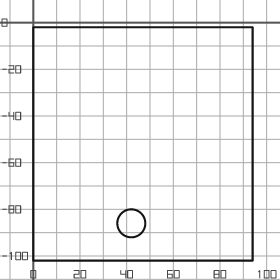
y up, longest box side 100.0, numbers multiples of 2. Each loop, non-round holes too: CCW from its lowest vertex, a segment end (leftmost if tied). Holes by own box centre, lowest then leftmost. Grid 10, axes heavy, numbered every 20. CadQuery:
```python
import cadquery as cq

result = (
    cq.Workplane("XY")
    .moveTo(0.0, -102.0)
    .lineTo(94.0, -102.0)
    .lineTo(94.0, -2.0)
    .lineTo(0.0, -2.0)
    .close()
    .moveTo(42.0, -86.0)
    .circle(6.0)
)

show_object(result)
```